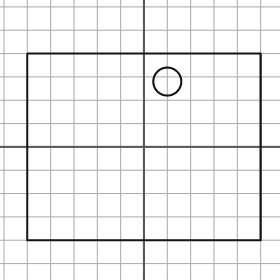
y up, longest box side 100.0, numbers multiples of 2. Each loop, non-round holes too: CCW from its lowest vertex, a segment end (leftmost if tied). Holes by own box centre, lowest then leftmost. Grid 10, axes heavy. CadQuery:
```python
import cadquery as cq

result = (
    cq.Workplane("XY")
    .moveTo(-50.0, -40.0)
    .lineTo(50.0, -40.0)
    .lineTo(50.0, 40.0)
    .lineTo(-50.0, 40.0)
    .close()
    .moveTo(10.0, 28.0)
    .circle(6.0)
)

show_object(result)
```